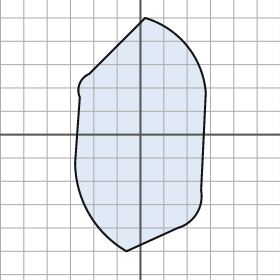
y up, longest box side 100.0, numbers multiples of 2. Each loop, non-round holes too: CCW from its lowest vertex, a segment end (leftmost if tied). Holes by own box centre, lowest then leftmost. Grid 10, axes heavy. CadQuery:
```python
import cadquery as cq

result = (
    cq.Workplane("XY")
    .moveTo(-6.0, -50.0)
    .lineTo(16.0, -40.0)
    .threePointArc((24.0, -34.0), (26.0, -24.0))
    .lineTo(28.0, 18.0)
    .threePointArc((20.0, 38.0), (2.0, 50.0))
    .lineTo(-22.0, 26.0)
    .threePointArc((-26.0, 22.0), (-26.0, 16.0))
    .lineTo(-28.0, -12.0)
    .threePointArc((-22.0, -34.0), (-6.0, -50.0))
    .close()
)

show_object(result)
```